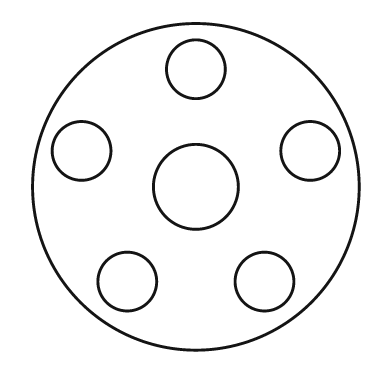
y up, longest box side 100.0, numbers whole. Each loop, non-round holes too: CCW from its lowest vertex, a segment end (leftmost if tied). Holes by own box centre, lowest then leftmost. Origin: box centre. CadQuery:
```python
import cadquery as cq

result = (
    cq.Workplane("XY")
    .moveTo(0.0, 0.0)
    .circle(50.0)
    .moveTo(-21.0, -29.0)
    .circle(9.0)
    .moveTo(21.0, -29.0)
    .circle(9.0)
    .moveTo(0.0, 0.0)
    .circle(13.0)
    .moveTo(-35.0, 11.0)
    .circle(9.0)
    .moveTo(35.0, 11.0)
    .circle(9.0)
    .moveTo(0.0, 36.0)
    .circle(9.0)
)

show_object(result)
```